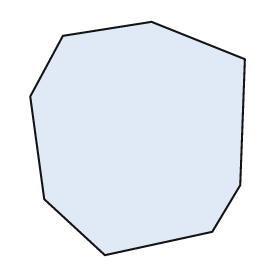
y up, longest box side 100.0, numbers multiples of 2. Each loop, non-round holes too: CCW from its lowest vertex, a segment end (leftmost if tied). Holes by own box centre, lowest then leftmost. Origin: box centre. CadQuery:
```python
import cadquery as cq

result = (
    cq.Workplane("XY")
    .moveTo(-14.0, -50.0)
    .lineTo(32.0, -40.0)
    .lineTo(44.0, -20.0)
    .lineTo(46.0, 34.0)
    .lineTo(6.0, 50.0)
    .lineTo(-32.0, 44.0)
    .lineTo(-46.0, 18.0)
    .lineTo(-40.0, -26.0)
    .close()
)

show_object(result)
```